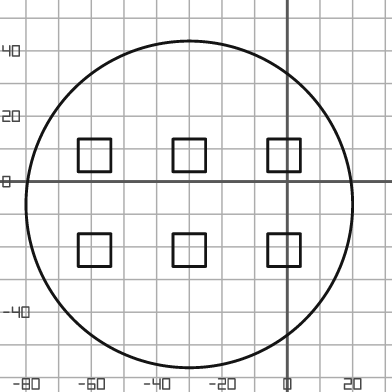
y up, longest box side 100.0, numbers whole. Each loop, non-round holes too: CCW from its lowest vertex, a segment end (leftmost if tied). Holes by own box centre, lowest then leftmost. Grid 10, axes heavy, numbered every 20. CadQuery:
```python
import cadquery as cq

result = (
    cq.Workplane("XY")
    .moveTo(-30.0, -7.0)
    .circle(50.0)
    .moveTo(-64.0, -26.0)
    .lineTo(-54.0, -26.0)
    .lineTo(-54.0, -16.0)
    .lineTo(-64.0, -16.0)
    .close()
    .moveTo(-35.0, -26.0)
    .lineTo(-25.0, -26.0)
    .lineTo(-25.0, -16.0)
    .lineTo(-35.0, -16.0)
    .close()
    .moveTo(-6.0, -26.0)
    .lineTo(4.0, -26.0)
    .lineTo(4.0, -16.0)
    .lineTo(-6.0, -16.0)
    .close()
    .moveTo(-64.0, 3.0)
    .lineTo(-54.0, 3.0)
    .lineTo(-54.0, 13.0)
    .lineTo(-64.0, 13.0)
    .close()
    .moveTo(-35.0, 3.0)
    .lineTo(-25.0, 3.0)
    .lineTo(-25.0, 13.0)
    .lineTo(-35.0, 13.0)
    .close()
    .moveTo(-6.0, 3.0)
    .lineTo(4.0, 3.0)
    .lineTo(4.0, 13.0)
    .lineTo(-6.0, 13.0)
    .close()
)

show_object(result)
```